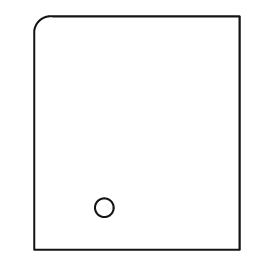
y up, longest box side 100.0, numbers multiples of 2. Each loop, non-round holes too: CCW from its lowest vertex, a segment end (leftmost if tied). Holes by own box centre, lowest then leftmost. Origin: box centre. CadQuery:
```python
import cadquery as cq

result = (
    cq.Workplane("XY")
    .moveTo(-44.0, -50.0)
    .lineTo(44.0, -50.0)
    .lineTo(44.0, 50.0)
    .lineTo(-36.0, 50.0)
    .threePointArc((-42.0, 48.0), (-44.0, 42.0))
    .close()
    .moveTo(-14.0, -32.0)
    .circle(4.0)
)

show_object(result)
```